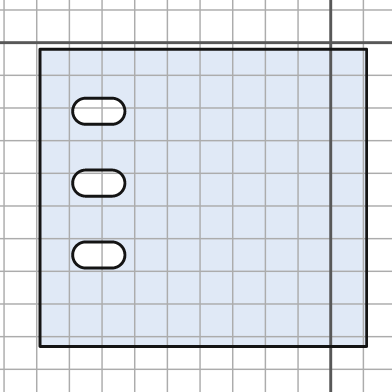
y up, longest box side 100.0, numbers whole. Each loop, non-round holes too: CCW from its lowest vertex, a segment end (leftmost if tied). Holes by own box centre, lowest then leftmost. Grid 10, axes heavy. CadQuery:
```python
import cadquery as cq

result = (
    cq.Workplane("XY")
    .moveTo(-89.0, -93.0)
    .lineTo(11.0, -93.0)
    .lineTo(11.0, -2.0)
    .lineTo(-89.0, -2.0)
    .close()
    .moveTo(-75.0, -69.0)
    .lineTo(-67.0, -69.0)
    .threePointArc((-63.0, -65.0), (-67.0, -61.0))
    .lineTo(-75.0, -61.0)
    .threePointArc((-79.0, -65.0), (-75.0, -69.0))
    .close()
    .moveTo(-75.0, -47.0)
    .lineTo(-67.0, -47.0)
    .threePointArc((-63.0, -43.0), (-67.0, -39.0))
    .lineTo(-75.0, -39.0)
    .threePointArc((-79.0, -43.0), (-75.0, -47.0))
    .close()
    .moveTo(-75.0, -25.0)
    .lineTo(-67.0, -25.0)
    .threePointArc((-63.0, -21.0), (-67.0, -17.0))
    .lineTo(-75.0, -17.0)
    .threePointArc((-79.0, -21.0), (-75.0, -25.0))
    .close()
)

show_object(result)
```